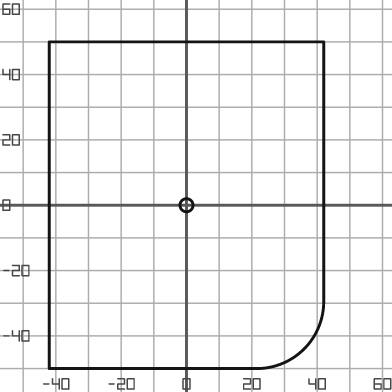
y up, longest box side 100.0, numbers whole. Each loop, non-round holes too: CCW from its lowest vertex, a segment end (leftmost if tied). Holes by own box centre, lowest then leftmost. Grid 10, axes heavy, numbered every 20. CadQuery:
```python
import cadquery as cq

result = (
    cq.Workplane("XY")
    .moveTo(-42.0, -50.0)
    .lineTo(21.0, -50.0)
    .threePointArc((36.0, -44.0), (42.0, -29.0))
    .lineTo(42.0, 50.0)
    .lineTo(-42.0, 50.0)
    .close()
    .moveTo(0.0, 0.0)
    .circle(2.0)
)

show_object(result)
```